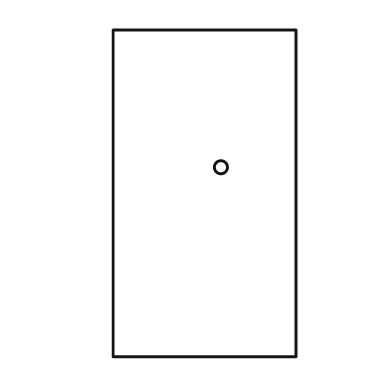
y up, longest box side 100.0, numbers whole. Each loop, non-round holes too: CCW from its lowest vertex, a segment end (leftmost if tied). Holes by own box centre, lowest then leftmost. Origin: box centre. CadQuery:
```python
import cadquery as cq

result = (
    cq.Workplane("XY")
    .moveTo(-28.0, -50.0)
    .lineTo(28.0, -50.0)
    .lineTo(28.0, 50.0)
    .lineTo(-28.0, 50.0)
    .close()
    .moveTo(5.0, 8.0)
    .circle(2.0)
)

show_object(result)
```